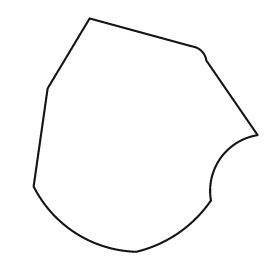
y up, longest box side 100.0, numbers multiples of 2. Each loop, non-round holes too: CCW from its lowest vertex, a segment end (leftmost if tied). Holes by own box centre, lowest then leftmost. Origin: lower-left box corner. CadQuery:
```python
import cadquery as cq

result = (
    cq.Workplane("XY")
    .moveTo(44.0, 0.0)
    .threePointArc((62.0, 8.0), (76.0, 22.0))
    .threePointArc((80.0, 40.0), (96.0, 50.0))
    .lineTo(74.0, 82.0)
    .threePointArc((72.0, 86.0), (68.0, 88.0))
    .lineTo(24.0, 100.0)
    .lineTo(6.0, 70.0)
    .lineTo(0.0, 28.0)
    .threePointArc((18.0, 8.0), (44.0, 0.0))
    .close()
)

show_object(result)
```